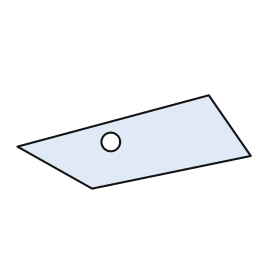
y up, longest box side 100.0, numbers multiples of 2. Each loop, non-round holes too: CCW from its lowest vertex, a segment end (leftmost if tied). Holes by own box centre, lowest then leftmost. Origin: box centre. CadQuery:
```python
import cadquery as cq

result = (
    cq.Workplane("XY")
    .moveTo(-18.0, -20.0)
    .lineTo(50.0, -6.0)
    .lineTo(32.0, 20.0)
    .lineTo(-50.0, -2.0)
    .close()
    .moveTo(-10.0, 0.0)
    .circle(4.0)
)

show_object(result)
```